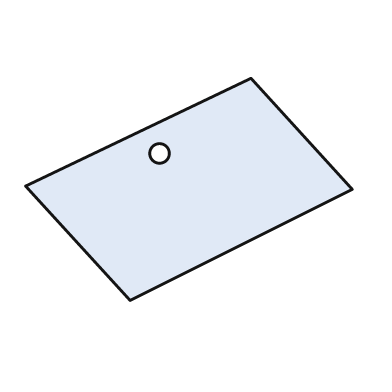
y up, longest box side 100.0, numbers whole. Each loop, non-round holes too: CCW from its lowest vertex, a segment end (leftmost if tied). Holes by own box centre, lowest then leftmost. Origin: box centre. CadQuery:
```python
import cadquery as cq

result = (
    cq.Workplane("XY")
    .moveTo(-18.0, -34.0)
    .lineTo(50.0, 0.0)
    .lineTo(19.0, 34.0)
    .lineTo(-50.0, 1.0)
    .close()
    .moveTo(-9.0, 11.0)
    .circle(3.0)
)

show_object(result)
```